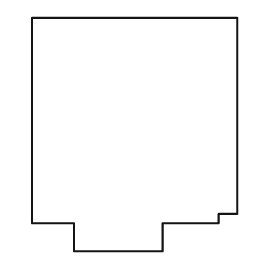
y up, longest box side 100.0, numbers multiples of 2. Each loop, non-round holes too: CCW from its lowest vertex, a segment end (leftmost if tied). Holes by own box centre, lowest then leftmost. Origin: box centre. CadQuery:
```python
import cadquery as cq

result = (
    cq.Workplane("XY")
    .moveTo(-26.0, -50.0)
    .lineTo(12.0, -50.0)
    .lineTo(12.0, -38.0)
    .lineTo(36.0, -38.0)
    .lineTo(36.0, -34.0)
    .lineTo(44.0, -34.0)
    .lineTo(44.0, 50.0)
    .lineTo(-44.0, 50.0)
    .lineTo(-44.0, -38.0)
    .lineTo(-26.0, -38.0)
    .close()
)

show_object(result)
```